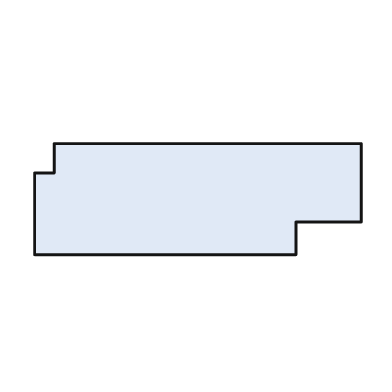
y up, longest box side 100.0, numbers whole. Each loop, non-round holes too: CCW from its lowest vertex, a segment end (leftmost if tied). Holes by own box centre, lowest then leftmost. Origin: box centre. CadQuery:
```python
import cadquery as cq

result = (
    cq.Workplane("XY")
    .moveTo(-50.0, -17.0)
    .lineTo(30.0, -17.0)
    .lineTo(30.0, -7.0)
    .lineTo(50.0, -7.0)
    .lineTo(50.0, 17.0)
    .lineTo(-44.0, 17.0)
    .lineTo(-44.0, 8.0)
    .lineTo(-50.0, 8.0)
    .close()
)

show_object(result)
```